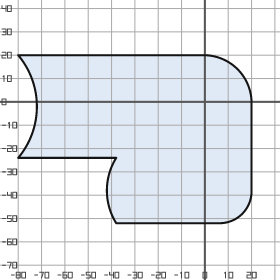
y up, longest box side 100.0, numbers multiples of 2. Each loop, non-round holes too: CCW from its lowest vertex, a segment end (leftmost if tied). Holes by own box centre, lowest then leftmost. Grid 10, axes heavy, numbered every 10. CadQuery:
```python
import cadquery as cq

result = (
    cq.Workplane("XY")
    .moveTo(-38.0, -52.0)
    .lineTo(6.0, -52.0)
    .threePointArc((16.0, -48.0), (20.0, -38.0))
    .lineTo(20.0, 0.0)
    .threePointArc((14.0, 14.0), (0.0, 20.0))
    .lineTo(-80.0, 20.0)
    .threePointArc((-72.0, -2.0), (-80.0, -24.0))
    .lineTo(-38.0, -24.0)
    .threePointArc((-42.0, -38.0), (-38.0, -52.0))
    .close()
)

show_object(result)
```